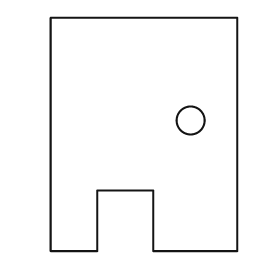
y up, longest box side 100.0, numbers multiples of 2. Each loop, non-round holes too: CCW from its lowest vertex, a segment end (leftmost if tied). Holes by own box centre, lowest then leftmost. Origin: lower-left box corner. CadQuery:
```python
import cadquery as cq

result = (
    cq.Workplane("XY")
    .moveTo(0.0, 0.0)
    .lineTo(20.0, 0.0)
    .lineTo(20.0, 26.0)
    .lineTo(44.0, 26.0)
    .lineTo(44.0, 0.0)
    .lineTo(80.0, 0.0)
    .lineTo(80.0, 100.0)
    .lineTo(0.0, 100.0)
    .close()
    .moveTo(60.0, 56.0)
    .circle(6.0)
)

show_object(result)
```